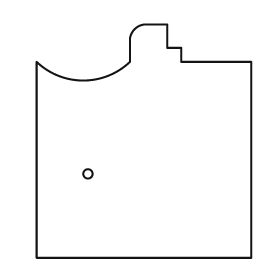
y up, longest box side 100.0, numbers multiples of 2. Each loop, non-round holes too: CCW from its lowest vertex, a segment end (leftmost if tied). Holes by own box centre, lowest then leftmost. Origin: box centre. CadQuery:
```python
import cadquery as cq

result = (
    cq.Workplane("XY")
    .moveTo(-46.0, -50.0)
    .lineTo(46.0, -50.0)
    .lineTo(46.0, 34.0)
    .lineTo(16.0, 34.0)
    .lineTo(16.0, 40.0)
    .lineTo(10.0, 40.0)
    .lineTo(10.0, 50.0)
    .lineTo(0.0, 50.0)
    .threePointArc((-4.0, 48.0), (-6.0, 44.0))
    .lineTo(-6.0, 34.0)
    .threePointArc((-26.0, 26.0), (-46.0, 34.0))
    .close()
    .moveTo(-24.0, -14.0)
    .circle(2.0)
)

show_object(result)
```